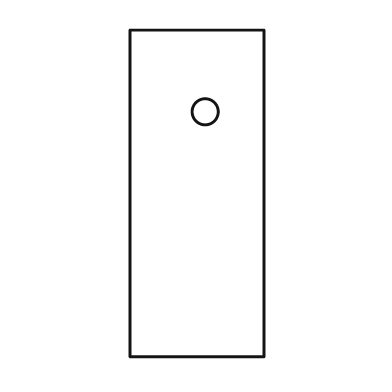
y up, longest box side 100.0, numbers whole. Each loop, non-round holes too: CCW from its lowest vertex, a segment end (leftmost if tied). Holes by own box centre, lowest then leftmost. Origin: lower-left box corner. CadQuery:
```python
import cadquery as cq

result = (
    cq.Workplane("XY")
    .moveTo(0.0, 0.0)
    .lineTo(41.0, 0.0)
    .lineTo(41.0, 100.0)
    .lineTo(0.0, 100.0)
    .close()
    .moveTo(23.0, 75.0)
    .circle(4.0)
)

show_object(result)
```